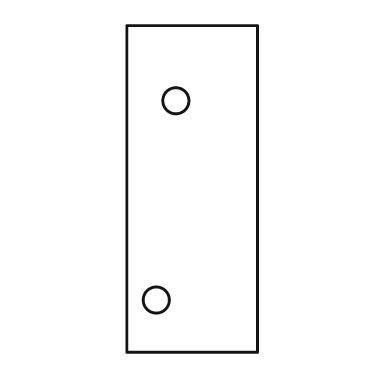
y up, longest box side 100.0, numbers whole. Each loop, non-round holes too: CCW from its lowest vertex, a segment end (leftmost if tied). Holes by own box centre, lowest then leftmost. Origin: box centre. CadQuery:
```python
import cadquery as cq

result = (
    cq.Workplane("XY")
    .moveTo(-20.0, -50.0)
    .lineTo(20.0, -50.0)
    .lineTo(20.0, 50.0)
    .lineTo(-20.0, 50.0)
    .close()
    .moveTo(-11.0, -34.0)
    .circle(4.0)
    .moveTo(-5.0, 27.0)
    .circle(4.0)
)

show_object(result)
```